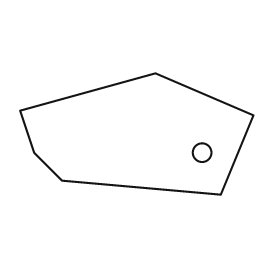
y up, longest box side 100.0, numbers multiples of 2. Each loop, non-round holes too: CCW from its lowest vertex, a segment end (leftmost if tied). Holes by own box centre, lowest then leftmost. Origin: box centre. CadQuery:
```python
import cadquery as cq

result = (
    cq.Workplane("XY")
    .moveTo(36.0, -26.0)
    .lineTo(50.0, 8.0)
    .lineTo(8.0, 26.0)
    .lineTo(-50.0, 10.0)
    .lineTo(-44.0, -8.0)
    .lineTo(-32.0, -20.0)
    .close()
    .moveTo(28.0, -8.0)
    .circle(4.0)
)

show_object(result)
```